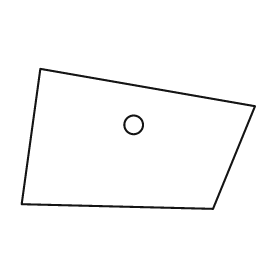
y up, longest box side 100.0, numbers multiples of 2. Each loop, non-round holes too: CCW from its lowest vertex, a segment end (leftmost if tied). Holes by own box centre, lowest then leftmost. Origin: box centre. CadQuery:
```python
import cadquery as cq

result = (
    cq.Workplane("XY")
    .moveTo(32.0, -30.0)
    .lineTo(50.0, 14.0)
    .lineTo(-42.0, 30.0)
    .lineTo(-50.0, -28.0)
    .close()
    .moveTo(-2.0, 6.0)
    .circle(4.0)
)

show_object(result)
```